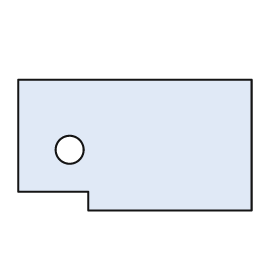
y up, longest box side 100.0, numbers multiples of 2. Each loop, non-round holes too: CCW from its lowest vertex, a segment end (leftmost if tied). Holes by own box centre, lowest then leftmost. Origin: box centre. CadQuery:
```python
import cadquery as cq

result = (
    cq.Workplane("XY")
    .moveTo(-20.0, -28.0)
    .lineTo(50.0, -28.0)
    .lineTo(50.0, 28.0)
    .lineTo(-50.0, 28.0)
    .lineTo(-50.0, -20.0)
    .lineTo(-20.0, -20.0)
    .close()
    .moveTo(-28.0, -2.0)
    .circle(6.0)
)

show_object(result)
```